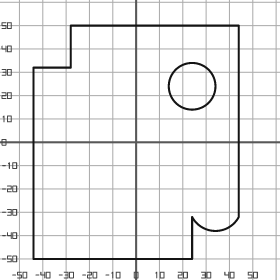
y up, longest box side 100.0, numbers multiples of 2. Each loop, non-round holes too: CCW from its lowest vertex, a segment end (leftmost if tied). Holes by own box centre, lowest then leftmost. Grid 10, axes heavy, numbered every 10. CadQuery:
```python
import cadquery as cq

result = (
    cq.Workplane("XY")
    .moveTo(-44.0, -50.0)
    .lineTo(24.0, -50.0)
    .lineTo(24.0, -32.0)
    .threePointArc((34.0, -38.0), (44.0, -32.0))
    .lineTo(44.0, 50.0)
    .lineTo(-28.0, 50.0)
    .lineTo(-28.0, 32.0)
    .lineTo(-44.0, 32.0)
    .close()
    .moveTo(24.0, 24.0)
    .circle(10.0)
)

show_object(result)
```